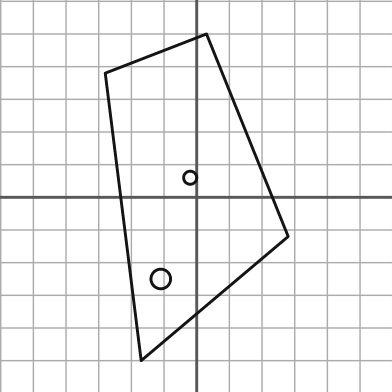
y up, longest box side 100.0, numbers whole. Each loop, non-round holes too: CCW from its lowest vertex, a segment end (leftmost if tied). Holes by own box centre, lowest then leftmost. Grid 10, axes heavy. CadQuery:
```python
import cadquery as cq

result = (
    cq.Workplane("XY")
    .moveTo(-17.0, -50.0)
    .lineTo(28.0, -12.0)
    .lineTo(3.0, 50.0)
    .lineTo(-28.0, 38.0)
    .close()
    .moveTo(-11.0, -25.0)
    .circle(3.0)
    .moveTo(-2.0, 6.0)
    .circle(2.0)
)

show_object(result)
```